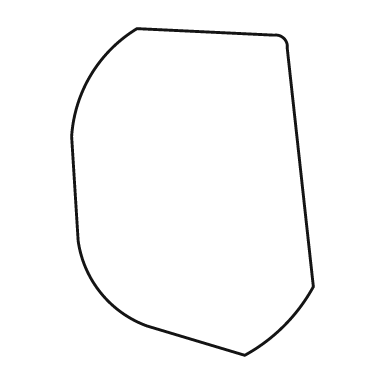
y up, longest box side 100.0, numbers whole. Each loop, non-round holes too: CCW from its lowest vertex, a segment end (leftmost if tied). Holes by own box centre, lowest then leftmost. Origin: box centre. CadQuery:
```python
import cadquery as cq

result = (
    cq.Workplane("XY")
    .moveTo(16.0, -50.0)
    .threePointArc((28.0, -41.0), (37.0, -29.0))
    .lineTo(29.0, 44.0)
    .threePointArc((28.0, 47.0), (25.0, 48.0))
    .lineTo(-17.0, 50.0)
    .threePointArc((-31.0, 36.0), (-37.0, 17.0))
    .lineTo(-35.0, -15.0)
    .threePointArc((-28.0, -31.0), (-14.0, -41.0))
    .close()
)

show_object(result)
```